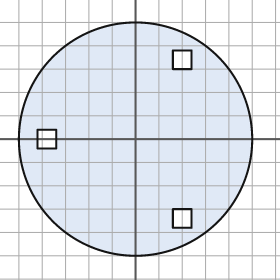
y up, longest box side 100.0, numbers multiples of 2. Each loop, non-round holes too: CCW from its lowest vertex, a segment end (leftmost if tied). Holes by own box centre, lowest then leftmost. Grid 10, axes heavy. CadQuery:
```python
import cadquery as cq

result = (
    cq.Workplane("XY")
    .moveTo(0.0, 0.0)
    .circle(50.0)
    .moveTo(16.0, -38.0)
    .lineTo(24.0, -38.0)
    .lineTo(24.0, -30.0)
    .lineTo(16.0, -30.0)
    .close()
    .moveTo(-42.0, -4.0)
    .lineTo(-34.0, -4.0)
    .lineTo(-34.0, 4.0)
    .lineTo(-42.0, 4.0)
    .close()
    .moveTo(16.0, 30.0)
    .lineTo(24.0, 30.0)
    .lineTo(24.0, 38.0)
    .lineTo(16.0, 38.0)
    .close()
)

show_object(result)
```